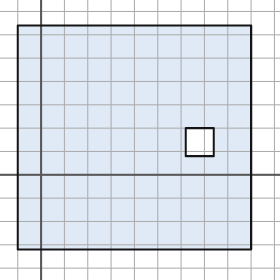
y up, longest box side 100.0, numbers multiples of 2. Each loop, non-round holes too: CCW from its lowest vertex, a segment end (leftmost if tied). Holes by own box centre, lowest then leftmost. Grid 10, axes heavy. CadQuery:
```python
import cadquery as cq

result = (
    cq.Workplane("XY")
    .moveTo(-10.0, -32.0)
    .lineTo(90.0, -32.0)
    .lineTo(90.0, 64.0)
    .lineTo(-10.0, 64.0)
    .close()
    .moveTo(62.0, 8.0)
    .lineTo(74.0, 8.0)
    .lineTo(74.0, 20.0)
    .lineTo(62.0, 20.0)
    .close()
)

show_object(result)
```